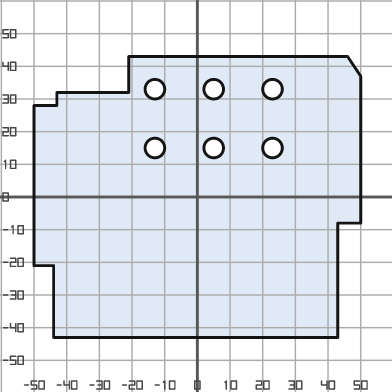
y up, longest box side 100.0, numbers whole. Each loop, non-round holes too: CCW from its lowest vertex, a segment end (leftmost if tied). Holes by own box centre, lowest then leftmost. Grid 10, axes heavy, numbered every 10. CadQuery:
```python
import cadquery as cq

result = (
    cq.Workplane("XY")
    .moveTo(-44.0, -43.0)
    .lineTo(43.0, -43.0)
    .lineTo(43.0, -8.0)
    .lineTo(50.0, -8.0)
    .lineTo(50.0, 37.0)
    .lineTo(46.0, 43.0)
    .lineTo(-21.0, 43.0)
    .lineTo(-21.0, 32.0)
    .lineTo(-43.0, 32.0)
    .lineTo(-43.0, 28.0)
    .lineTo(-50.0, 28.0)
    .lineTo(-50.0, -21.0)
    .lineTo(-44.0, -21.0)
    .close()
    .moveTo(-13.0, 15.0)
    .circle(3.0)
    .moveTo(5.0, 15.0)
    .circle(3.0)
    .moveTo(23.0, 15.0)
    .circle(3.0)
    .moveTo(-13.0, 33.0)
    .circle(3.0)
    .moveTo(5.0, 33.0)
    .circle(3.0)
    .moveTo(23.0, 33.0)
    .circle(3.0)
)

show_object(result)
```